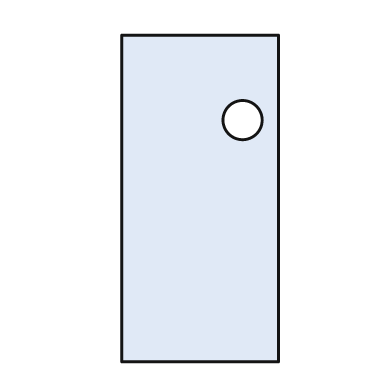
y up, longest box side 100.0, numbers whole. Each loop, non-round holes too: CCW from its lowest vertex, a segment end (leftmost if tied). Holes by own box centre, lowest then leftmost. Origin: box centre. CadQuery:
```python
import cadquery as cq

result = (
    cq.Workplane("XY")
    .moveTo(-24.0, -50.0)
    .lineTo(24.0, -50.0)
    .lineTo(24.0, 50.0)
    .lineTo(-24.0, 50.0)
    .close()
    .moveTo(13.0, 24.0)
    .circle(6.0)
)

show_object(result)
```